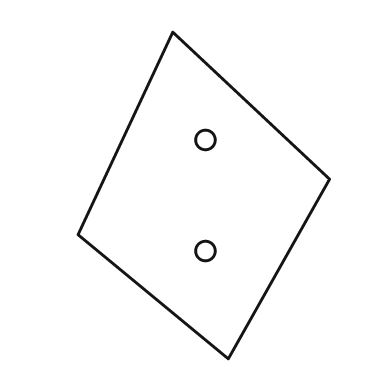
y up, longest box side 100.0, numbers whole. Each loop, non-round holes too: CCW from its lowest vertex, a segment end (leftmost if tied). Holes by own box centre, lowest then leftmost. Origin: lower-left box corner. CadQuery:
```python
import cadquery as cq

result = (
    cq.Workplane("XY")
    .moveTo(46.0, 0.0)
    .lineTo(77.0, 55.0)
    .lineTo(29.0, 100.0)
    .lineTo(0.0, 38.0)
    .close()
    .moveTo(39.0, 33.0)
    .circle(3.0)
    .moveTo(39.0, 67.0)
    .circle(3.0)
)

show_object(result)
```